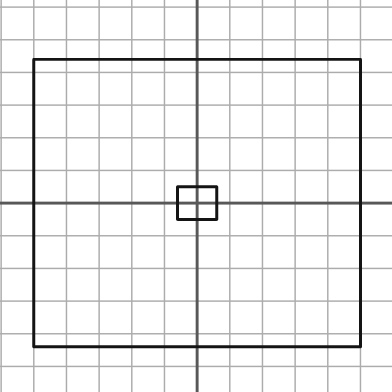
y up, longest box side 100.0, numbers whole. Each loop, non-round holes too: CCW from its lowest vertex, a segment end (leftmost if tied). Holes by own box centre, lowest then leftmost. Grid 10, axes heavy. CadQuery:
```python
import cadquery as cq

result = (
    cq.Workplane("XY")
    .moveTo(-50.0, -44.0)
    .lineTo(50.0, -44.0)
    .lineTo(50.0, 44.0)
    .lineTo(-50.0, 44.0)
    .close()
    .moveTo(-6.0, -5.0)
    .lineTo(6.0, -5.0)
    .lineTo(6.0, 5.0)
    .lineTo(-6.0, 5.0)
    .close()
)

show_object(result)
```